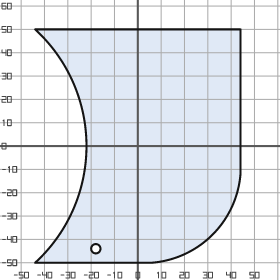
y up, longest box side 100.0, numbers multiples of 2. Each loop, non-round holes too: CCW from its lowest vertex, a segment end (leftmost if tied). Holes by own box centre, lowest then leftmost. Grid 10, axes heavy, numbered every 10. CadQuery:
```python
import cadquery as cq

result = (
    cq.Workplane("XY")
    .moveTo(-44.0, -50.0)
    .lineTo(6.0, -50.0)
    .threePointArc((32.0, -38.0), (44.0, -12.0))
    .lineTo(44.0, 50.0)
    .lineTo(-44.0, 50.0)
    .threePointArc((-22.0, 0.0), (-44.0, -50.0))
    .close()
    .moveTo(-18.0, -44.0)
    .circle(2.0)
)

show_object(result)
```